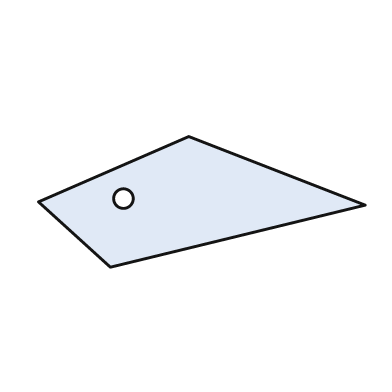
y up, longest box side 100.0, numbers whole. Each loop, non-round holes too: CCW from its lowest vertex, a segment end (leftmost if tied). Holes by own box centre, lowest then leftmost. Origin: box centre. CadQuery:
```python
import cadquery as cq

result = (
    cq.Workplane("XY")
    .moveTo(-28.0, -20.0)
    .lineTo(50.0, -1.0)
    .lineTo(-4.0, 20.0)
    .lineTo(-50.0, 0.0)
    .close()
    .moveTo(-24.0, 1.0)
    .circle(3.0)
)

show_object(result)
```